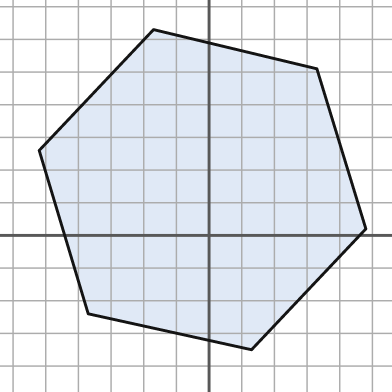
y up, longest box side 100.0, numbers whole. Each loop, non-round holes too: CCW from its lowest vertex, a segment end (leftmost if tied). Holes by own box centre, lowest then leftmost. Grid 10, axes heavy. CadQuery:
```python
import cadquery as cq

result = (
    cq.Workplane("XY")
    .moveTo(13.0, -35.0)
    .lineTo(48.0, 2.0)
    .lineTo(33.0, 51.0)
    .lineTo(-17.0, 63.0)
    .lineTo(-52.0, 26.0)
    .lineTo(-37.0, -24.0)
    .close()
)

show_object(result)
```